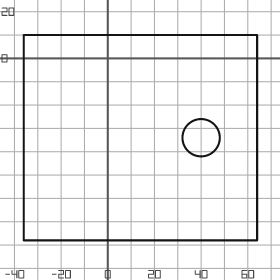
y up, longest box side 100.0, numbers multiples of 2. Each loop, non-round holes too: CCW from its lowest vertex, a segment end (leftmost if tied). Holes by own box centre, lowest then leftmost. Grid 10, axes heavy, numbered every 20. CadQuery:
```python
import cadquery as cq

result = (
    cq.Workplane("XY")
    .moveTo(-36.0, -78.0)
    .lineTo(64.0, -78.0)
    .lineTo(64.0, 10.0)
    .lineTo(-36.0, 10.0)
    .close()
    .moveTo(40.0, -34.0)
    .circle(8.0)
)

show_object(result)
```